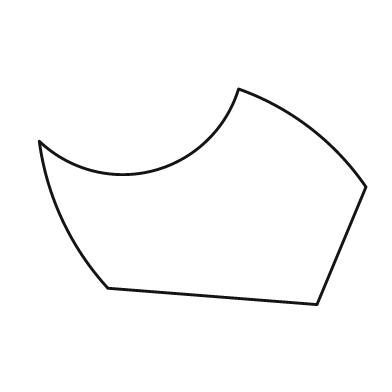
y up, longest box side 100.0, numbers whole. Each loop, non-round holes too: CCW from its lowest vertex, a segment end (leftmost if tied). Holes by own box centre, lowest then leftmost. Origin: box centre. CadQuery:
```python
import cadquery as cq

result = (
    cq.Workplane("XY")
    .moveTo(35.0, -33.0)
    .lineTo(50.0, 3.0)
    .threePointArc((33.0, 21.0), (11.0, 33.0))
    .threePointArc((-15.0, 8.0), (-50.0, 17.0))
    .threePointArc((-43.0, -7.0), (-29.0, -28.0))
    .close()
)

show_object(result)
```